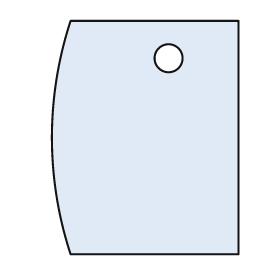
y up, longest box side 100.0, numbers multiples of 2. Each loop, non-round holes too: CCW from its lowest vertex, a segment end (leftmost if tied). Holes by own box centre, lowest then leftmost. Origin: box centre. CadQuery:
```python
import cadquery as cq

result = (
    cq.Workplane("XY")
    .moveTo(-32.0, -50.0)
    .lineTo(40.0, -50.0)
    .lineTo(40.0, 50.0)
    .lineTo(-32.0, 50.0)
    .threePointArc((-40.0, 0.0), (-32.0, -50.0))
    .close()
    .moveTo(10.0, 34.0)
    .circle(6.0)
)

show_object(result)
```